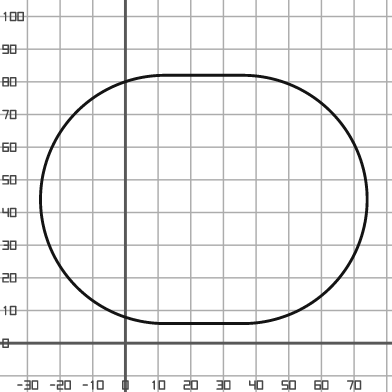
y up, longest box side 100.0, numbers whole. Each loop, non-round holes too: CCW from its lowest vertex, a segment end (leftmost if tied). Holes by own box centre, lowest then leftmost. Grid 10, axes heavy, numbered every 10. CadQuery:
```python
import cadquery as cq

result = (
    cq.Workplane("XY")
    .moveTo(12.0, 6.0)
    .lineTo(36.0, 6.0)
    .threePointArc((74.0, 44.0), (36.0, 82.0))
    .lineTo(12.0, 82.0)
    .threePointArc((-26.0, 44.0), (12.0, 6.0))
    .close()
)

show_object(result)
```